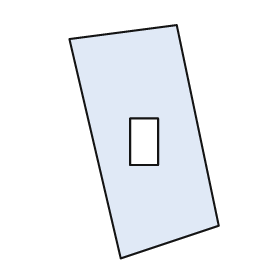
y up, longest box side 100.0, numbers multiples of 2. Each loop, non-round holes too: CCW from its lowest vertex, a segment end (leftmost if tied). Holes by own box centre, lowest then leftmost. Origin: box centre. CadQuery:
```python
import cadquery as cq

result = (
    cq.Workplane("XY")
    .moveTo(-10.0, -50.0)
    .lineTo(32.0, -36.0)
    .lineTo(14.0, 50.0)
    .lineTo(-32.0, 44.0)
    .close()
    .moveTo(-6.0, -10.0)
    .lineTo(6.0, -10.0)
    .lineTo(6.0, 10.0)
    .lineTo(-6.0, 10.0)
    .close()
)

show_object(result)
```